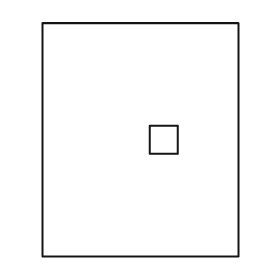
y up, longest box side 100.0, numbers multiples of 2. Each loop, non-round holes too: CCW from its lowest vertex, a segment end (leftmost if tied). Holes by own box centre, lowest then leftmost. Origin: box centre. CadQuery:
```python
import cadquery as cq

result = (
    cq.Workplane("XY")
    .moveTo(-42.0, -50.0)
    .lineTo(42.0, -50.0)
    .lineTo(42.0, 50.0)
    .lineTo(-42.0, 50.0)
    .close()
    .moveTo(4.0, -6.0)
    .lineTo(16.0, -6.0)
    .lineTo(16.0, 6.0)
    .lineTo(4.0, 6.0)
    .close()
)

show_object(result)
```